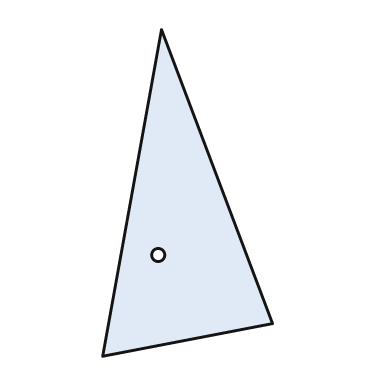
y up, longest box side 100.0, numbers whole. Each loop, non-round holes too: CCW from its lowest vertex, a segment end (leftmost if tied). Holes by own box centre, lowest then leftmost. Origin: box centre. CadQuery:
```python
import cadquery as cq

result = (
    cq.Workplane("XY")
    .moveTo(-26.0, -50.0)
    .lineTo(26.0, -40.0)
    .lineTo(-8.0, 50.0)
    .close()
    .moveTo(-9.0, -19.0)
    .circle(2.0)
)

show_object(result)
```